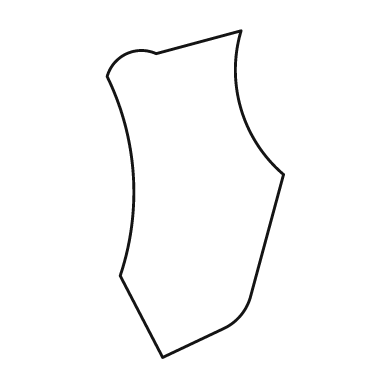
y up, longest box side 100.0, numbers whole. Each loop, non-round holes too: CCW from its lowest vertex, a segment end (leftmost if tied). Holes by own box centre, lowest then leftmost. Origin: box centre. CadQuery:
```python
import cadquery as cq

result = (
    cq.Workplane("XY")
    .moveTo(-10.0, -50.0)
    .lineTo(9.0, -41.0)
    .threePointArc((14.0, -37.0), (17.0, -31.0))
    .lineTo(27.0, 6.0)
    .threePointArc((14.0, 26.0), (14.0, 50.0))
    .lineTo(-12.0, 43.0)
    .threePointArc((-21.0, 43.0), (-27.0, 36.0))
    .threePointArc((-19.0, 6.0), (-23.0, -25.0))
    .close()
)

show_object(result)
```